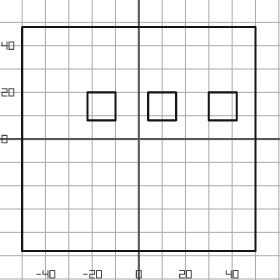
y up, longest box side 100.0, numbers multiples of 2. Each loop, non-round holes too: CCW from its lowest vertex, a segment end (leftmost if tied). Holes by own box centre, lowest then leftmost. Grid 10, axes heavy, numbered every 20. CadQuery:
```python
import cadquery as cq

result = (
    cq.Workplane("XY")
    .moveTo(-50.0, -48.0)
    .lineTo(50.0, -48.0)
    .lineTo(50.0, 48.0)
    .lineTo(-50.0, 48.0)
    .close()
    .moveTo(-22.0, 8.0)
    .lineTo(-10.0, 8.0)
    .lineTo(-10.0, 20.0)
    .lineTo(-22.0, 20.0)
    .close()
    .moveTo(4.0, 8.0)
    .lineTo(16.0, 8.0)
    .lineTo(16.0, 20.0)
    .lineTo(4.0, 20.0)
    .close()
    .moveTo(30.0, 8.0)
    .lineTo(42.0, 8.0)
    .lineTo(42.0, 20.0)
    .lineTo(30.0, 20.0)
    .close()
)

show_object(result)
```